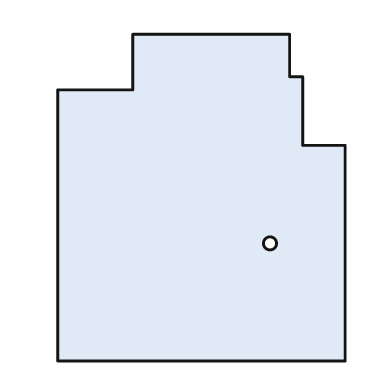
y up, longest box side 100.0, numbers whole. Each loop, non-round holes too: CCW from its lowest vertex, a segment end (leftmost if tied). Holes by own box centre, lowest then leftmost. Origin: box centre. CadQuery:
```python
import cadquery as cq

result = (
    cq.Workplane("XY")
    .moveTo(-44.0, -50.0)
    .lineTo(44.0, -50.0)
    .lineTo(44.0, 16.0)
    .lineTo(31.0, 16.0)
    .lineTo(31.0, 37.0)
    .lineTo(27.0, 37.0)
    .lineTo(27.0, 50.0)
    .lineTo(-21.0, 50.0)
    .lineTo(-21.0, 33.0)
    .lineTo(-44.0, 33.0)
    .close()
    .moveTo(21.0, -14.0)
    .circle(2.0)
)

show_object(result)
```